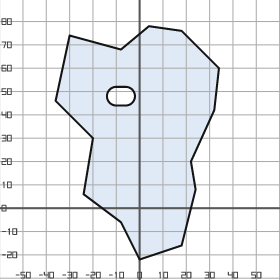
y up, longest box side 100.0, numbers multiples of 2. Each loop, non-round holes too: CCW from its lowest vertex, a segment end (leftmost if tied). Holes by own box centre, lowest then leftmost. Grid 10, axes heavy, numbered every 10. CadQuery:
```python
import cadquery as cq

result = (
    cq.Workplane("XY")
    .moveTo(0.0, -22.0)
    .lineTo(18.0, -16.0)
    .lineTo(24.0, 8.0)
    .lineTo(22.0, 20.0)
    .lineTo(32.0, 42.0)
    .lineTo(34.0, 60.0)
    .lineTo(18.0, 76.0)
    .lineTo(4.0, 78.0)
    .lineTo(-8.0, 68.0)
    .lineTo(-30.0, 74.0)
    .lineTo(-36.0, 46.0)
    .lineTo(-20.0, 30.0)
    .lineTo(-24.0, 6.0)
    .lineTo(-8.0, -6.0)
    .close()
    .moveTo(-10.0, 44.0)
    .lineTo(-6.0, 44.0)
    .threePointArc((-2.0, 48.0), (-6.0, 52.0))
    .lineTo(-10.0, 52.0)
    .threePointArc((-14.0, 48.0), (-10.0, 44.0))
    .close()
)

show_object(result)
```